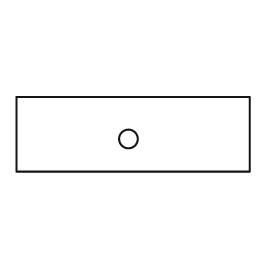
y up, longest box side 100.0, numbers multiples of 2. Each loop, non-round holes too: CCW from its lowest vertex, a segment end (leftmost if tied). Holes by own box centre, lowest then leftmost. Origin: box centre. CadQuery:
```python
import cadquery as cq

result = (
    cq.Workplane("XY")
    .moveTo(-50.0, -16.0)
    .lineTo(50.0, -16.0)
    .lineTo(50.0, 16.0)
    .lineTo(-50.0, 16.0)
    .close()
    .moveTo(-2.0, -2.0)
    .circle(4.0)
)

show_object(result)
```